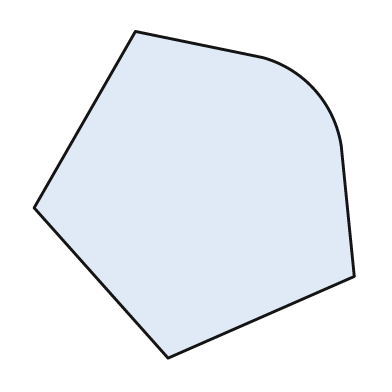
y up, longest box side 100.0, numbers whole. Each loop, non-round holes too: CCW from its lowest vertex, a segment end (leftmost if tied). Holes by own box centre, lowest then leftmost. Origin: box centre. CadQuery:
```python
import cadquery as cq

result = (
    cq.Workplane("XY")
    .moveTo(-8.0, -50.0)
    .lineTo(49.0, -25.0)
    .lineTo(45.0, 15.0)
    .threePointArc((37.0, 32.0), (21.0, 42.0))
    .lineTo(-18.0, 50.0)
    .lineTo(-49.0, -4.0)
    .close()
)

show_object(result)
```